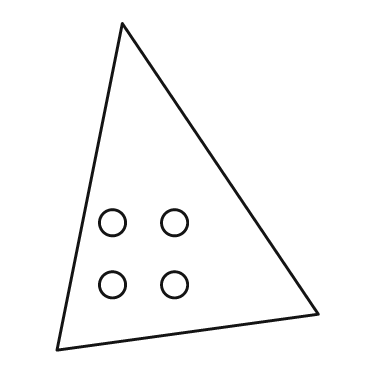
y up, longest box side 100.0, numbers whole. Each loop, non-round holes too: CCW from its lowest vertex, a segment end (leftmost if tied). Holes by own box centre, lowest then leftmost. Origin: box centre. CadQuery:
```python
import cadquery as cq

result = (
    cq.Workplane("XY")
    .moveTo(-40.0, -50.0)
    .lineTo(40.0, -39.0)
    .lineTo(-20.0, 50.0)
    .close()
    .moveTo(-23.0, -30.0)
    .circle(4.0)
    .moveTo(-4.0, -30.0)
    .circle(4.0)
    .moveTo(-23.0, -11.0)
    .circle(4.0)
    .moveTo(-4.0, -11.0)
    .circle(4.0)
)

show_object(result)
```